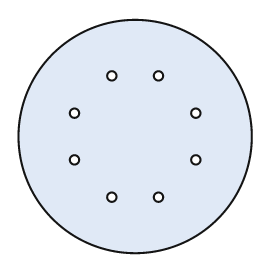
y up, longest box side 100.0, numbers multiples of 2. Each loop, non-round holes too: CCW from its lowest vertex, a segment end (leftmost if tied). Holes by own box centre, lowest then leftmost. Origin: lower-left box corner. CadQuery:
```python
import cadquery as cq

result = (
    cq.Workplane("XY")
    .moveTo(50.0, 50.0)
    .circle(50.0)
    .moveTo(40.0, 24.0)
    .circle(2.0)
    .moveTo(60.0, 24.0)
    .circle(2.0)
    .moveTo(24.0, 40.0)
    .circle(2.0)
    .moveTo(76.0, 40.0)
    .circle(2.0)
    .moveTo(24.0, 60.0)
    .circle(2.0)
    .moveTo(76.0, 60.0)
    .circle(2.0)
    .moveTo(40.0, 76.0)
    .circle(2.0)
    .moveTo(60.0, 76.0)
    .circle(2.0)
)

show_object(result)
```